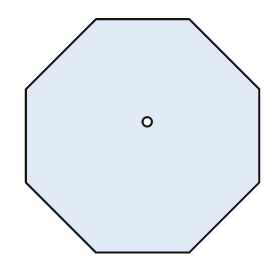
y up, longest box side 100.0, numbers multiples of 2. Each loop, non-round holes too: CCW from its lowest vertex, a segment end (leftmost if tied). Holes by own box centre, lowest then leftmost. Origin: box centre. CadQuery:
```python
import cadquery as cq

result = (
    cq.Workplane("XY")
    .moveTo(-20.0, -50.0)
    .lineTo(20.0, -50.0)
    .lineTo(50.0, -20.0)
    .lineTo(50.0, 20.0)
    .lineTo(20.0, 50.0)
    .lineTo(-20.0, 50.0)
    .lineTo(-50.0, 20.0)
    .lineTo(-50.0, -20.0)
    .close()
    .moveTo(2.0, 6.0)
    .circle(2.0)
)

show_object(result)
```